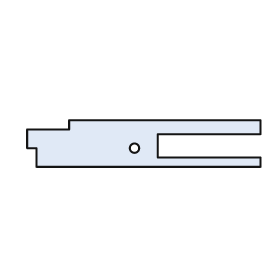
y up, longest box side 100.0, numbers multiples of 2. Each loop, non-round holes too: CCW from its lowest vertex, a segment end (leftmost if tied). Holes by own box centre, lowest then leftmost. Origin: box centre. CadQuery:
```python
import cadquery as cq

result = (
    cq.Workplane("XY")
    .moveTo(-46.0, -10.0)
    .lineTo(50.0, -10.0)
    .lineTo(50.0, -6.0)
    .lineTo(6.0, -6.0)
    .lineTo(6.0, 4.0)
    .lineTo(50.0, 4.0)
    .lineTo(50.0, 10.0)
    .lineTo(-32.0, 10.0)
    .lineTo(-32.0, 6.0)
    .lineTo(-50.0, 6.0)
    .lineTo(-50.0, -2.0)
    .lineTo(-46.0, -2.0)
    .close()
    .moveTo(-4.0, -2.0)
    .circle(2.0)
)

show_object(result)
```